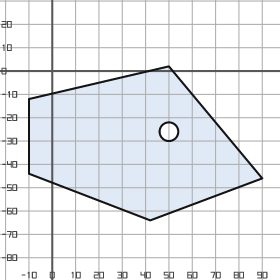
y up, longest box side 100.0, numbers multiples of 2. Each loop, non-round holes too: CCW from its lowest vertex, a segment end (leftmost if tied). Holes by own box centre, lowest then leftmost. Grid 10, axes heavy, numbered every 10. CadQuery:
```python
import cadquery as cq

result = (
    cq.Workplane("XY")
    .moveTo(42.0, -64.0)
    .lineTo(90.0, -46.0)
    .lineTo(50.0, 2.0)
    .lineTo(-10.0, -12.0)
    .lineTo(-10.0, -44.0)
    .close()
    .moveTo(50.0, -26.0)
    .circle(4.0)
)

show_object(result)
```